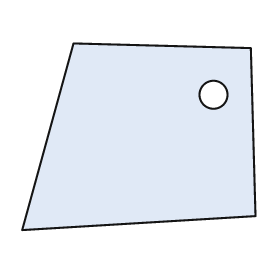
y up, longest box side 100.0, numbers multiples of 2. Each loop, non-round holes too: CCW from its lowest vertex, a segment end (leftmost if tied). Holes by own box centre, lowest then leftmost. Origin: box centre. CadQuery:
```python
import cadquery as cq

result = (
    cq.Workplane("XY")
    .moveTo(-50.0, -40.0)
    .lineTo(50.0, -34.0)
    .lineTo(48.0, 38.0)
    .lineTo(-28.0, 40.0)
    .close()
    .moveTo(32.0, 18.0)
    .circle(6.0)
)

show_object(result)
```